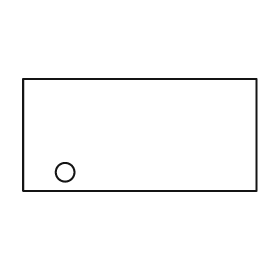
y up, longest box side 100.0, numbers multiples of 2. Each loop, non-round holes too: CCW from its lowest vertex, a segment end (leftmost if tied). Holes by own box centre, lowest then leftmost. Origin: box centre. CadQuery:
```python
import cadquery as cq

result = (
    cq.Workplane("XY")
    .moveTo(-50.0, -24.0)
    .lineTo(50.0, -24.0)
    .lineTo(50.0, 24.0)
    .lineTo(-50.0, 24.0)
    .close()
    .moveTo(-32.0, -16.0)
    .circle(4.0)
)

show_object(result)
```